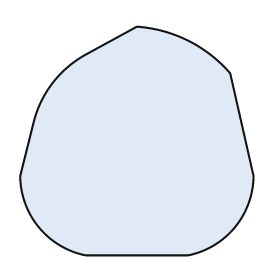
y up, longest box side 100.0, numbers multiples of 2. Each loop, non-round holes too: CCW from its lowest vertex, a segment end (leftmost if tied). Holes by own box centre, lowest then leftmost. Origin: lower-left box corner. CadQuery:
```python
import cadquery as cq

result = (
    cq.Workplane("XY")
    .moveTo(28.0, 0.0)
    .lineTo(72.0, 0.0)
    .threePointArc((92.0, 12.0), (100.0, 34.0))
    .lineTo(90.0, 78.0)
    .threePointArc((72.0, 92.0), (50.0, 98.0))
    .lineTo(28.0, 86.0)
    .threePointArc((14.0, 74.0), (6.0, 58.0))
    .lineTo(0.0, 34.0)
    .threePointArc((8.0, 12.0), (28.0, 0.0))
    .close()
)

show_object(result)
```